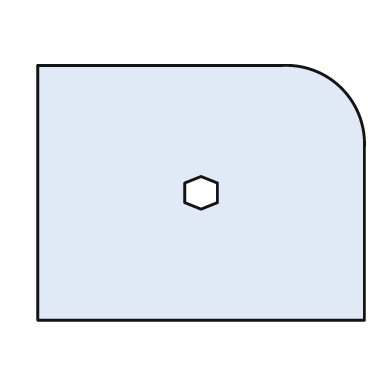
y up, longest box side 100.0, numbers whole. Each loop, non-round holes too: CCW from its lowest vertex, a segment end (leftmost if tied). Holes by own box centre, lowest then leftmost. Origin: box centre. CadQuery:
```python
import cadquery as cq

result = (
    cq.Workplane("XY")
    .moveTo(-50.0, -39.0)
    .lineTo(50.0, -39.0)
    .lineTo(50.0, 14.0)
    .threePointArc((43.0, 32.0), (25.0, 39.0))
    .lineTo(-50.0, 39.0)
    .close()
    .moveTo(0.0, -5.0)
    .lineTo(5.0, -3.0)
    .lineTo(5.0, 3.0)
    .lineTo(0.0, 5.0)
    .lineTo(-5.0, 3.0)
    .lineTo(-5.0, -3.0)
    .close()
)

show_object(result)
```